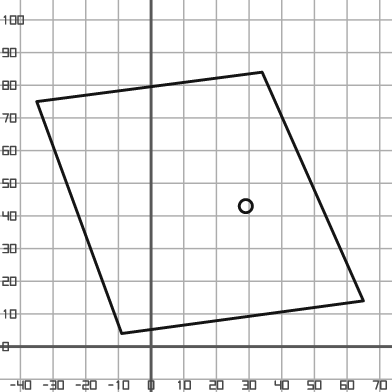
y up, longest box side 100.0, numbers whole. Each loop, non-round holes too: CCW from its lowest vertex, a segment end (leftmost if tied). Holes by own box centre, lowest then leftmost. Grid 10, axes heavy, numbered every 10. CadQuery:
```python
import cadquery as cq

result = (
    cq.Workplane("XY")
    .moveTo(-9.0, 4.0)
    .lineTo(65.0, 14.0)
    .lineTo(34.0, 84.0)
    .lineTo(-35.0, 75.0)
    .close()
    .moveTo(29.0, 43.0)
    .circle(2.0)
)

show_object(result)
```